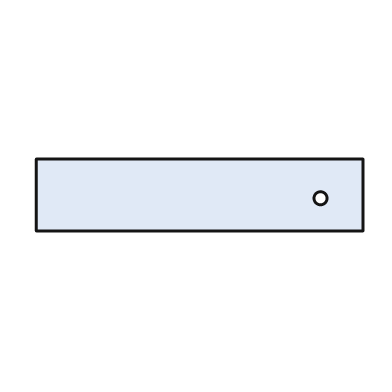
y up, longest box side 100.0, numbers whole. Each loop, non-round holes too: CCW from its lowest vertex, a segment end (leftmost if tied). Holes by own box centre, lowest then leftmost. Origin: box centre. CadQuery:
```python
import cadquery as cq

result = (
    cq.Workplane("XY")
    .moveTo(-50.0, -11.0)
    .lineTo(50.0, -11.0)
    .lineTo(50.0, 11.0)
    .lineTo(-50.0, 11.0)
    .close()
    .moveTo(37.0, -1.0)
    .circle(2.0)
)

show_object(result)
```